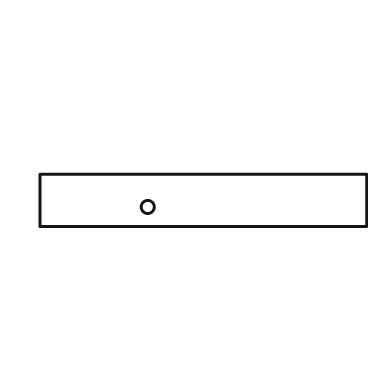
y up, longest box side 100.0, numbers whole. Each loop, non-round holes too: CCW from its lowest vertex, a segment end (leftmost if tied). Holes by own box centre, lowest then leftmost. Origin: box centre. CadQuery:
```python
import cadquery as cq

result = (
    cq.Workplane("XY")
    .moveTo(-50.0, -8.0)
    .lineTo(50.0, -8.0)
    .lineTo(50.0, 8.0)
    .lineTo(-50.0, 8.0)
    .close()
    .moveTo(-17.0, -2.0)
    .circle(2.0)
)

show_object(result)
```